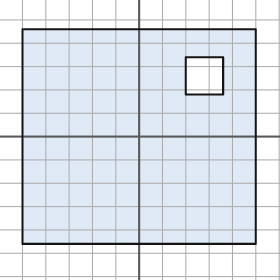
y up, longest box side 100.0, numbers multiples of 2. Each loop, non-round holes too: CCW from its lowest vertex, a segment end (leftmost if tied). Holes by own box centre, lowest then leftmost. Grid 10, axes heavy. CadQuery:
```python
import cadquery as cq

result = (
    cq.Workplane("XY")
    .moveTo(-50.0, -46.0)
    .lineTo(50.0, -46.0)
    .lineTo(50.0, 46.0)
    .lineTo(-50.0, 46.0)
    .close()
    .moveTo(20.0, 18.0)
    .lineTo(36.0, 18.0)
    .lineTo(36.0, 34.0)
    .lineTo(20.0, 34.0)
    .close()
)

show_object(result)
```